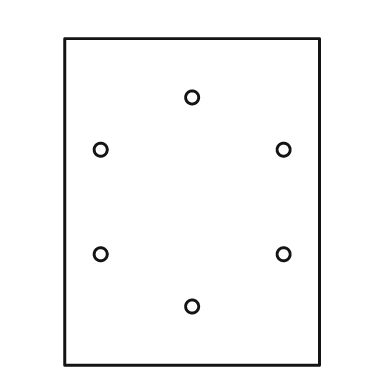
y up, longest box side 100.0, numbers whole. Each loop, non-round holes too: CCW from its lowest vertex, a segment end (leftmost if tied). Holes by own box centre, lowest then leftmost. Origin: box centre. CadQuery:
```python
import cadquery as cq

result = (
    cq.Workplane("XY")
    .moveTo(-39.0, -50.0)
    .lineTo(39.0, -50.0)
    .lineTo(39.0, 50.0)
    .lineTo(-39.0, 50.0)
    .close()
    .moveTo(0.0, -32.0)
    .circle(2.0)
    .moveTo(-28.0, -16.0)
    .circle(2.0)
    .moveTo(28.0, -16.0)
    .circle(2.0)
    .moveTo(-28.0, 16.0)
    .circle(2.0)
    .moveTo(28.0, 16.0)
    .circle(2.0)
    .moveTo(0.0, 32.0)
    .circle(2.0)
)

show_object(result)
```